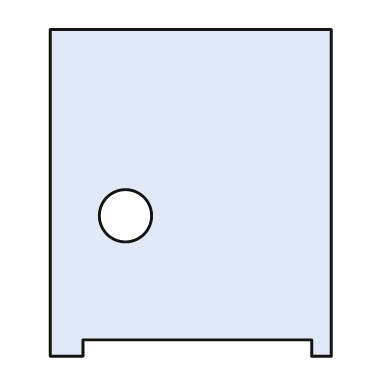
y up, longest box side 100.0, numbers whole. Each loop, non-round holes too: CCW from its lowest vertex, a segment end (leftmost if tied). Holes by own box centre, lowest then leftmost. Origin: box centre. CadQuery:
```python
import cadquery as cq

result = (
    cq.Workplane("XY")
    .moveTo(-43.0, -50.0)
    .lineTo(-33.0, -50.0)
    .lineTo(-33.0, -45.0)
    .lineTo(37.0, -45.0)
    .lineTo(37.0, -50.0)
    .lineTo(43.0, -50.0)
    .lineTo(43.0, 50.0)
    .lineTo(-43.0, 50.0)
    .close()
    .moveTo(-20.0, -7.0)
    .circle(8.0)
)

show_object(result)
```